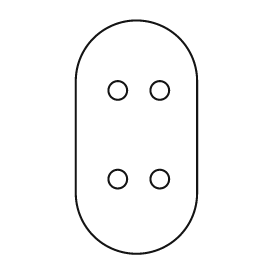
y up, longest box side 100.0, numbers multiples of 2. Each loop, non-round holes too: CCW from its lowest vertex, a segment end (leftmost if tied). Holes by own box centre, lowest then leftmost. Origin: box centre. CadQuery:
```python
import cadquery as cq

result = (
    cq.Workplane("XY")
    .moveTo(-26.0, -24.0)
    .threePointArc((0.0, -50.0), (26.0, -24.0))
    .lineTo(26.0, 24.0)
    .threePointArc((0.0, 50.0), (-26.0, 24.0))
    .close()
    .moveTo(-8.0, -18.0)
    .circle(4.0)
    .moveTo(10.0, -18.0)
    .circle(4.0)
    .moveTo(-8.0, 20.0)
    .circle(4.0)
    .moveTo(10.0, 20.0)
    .circle(4.0)
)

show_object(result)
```